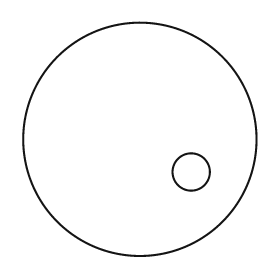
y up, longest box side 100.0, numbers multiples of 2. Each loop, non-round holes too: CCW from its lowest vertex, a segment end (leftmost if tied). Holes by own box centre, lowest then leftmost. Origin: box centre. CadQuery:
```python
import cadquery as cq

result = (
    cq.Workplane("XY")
    .moveTo(0.0, 0.0)
    .circle(50.0)
    .moveTo(22.0, -14.0)
    .circle(8.0)
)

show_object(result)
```